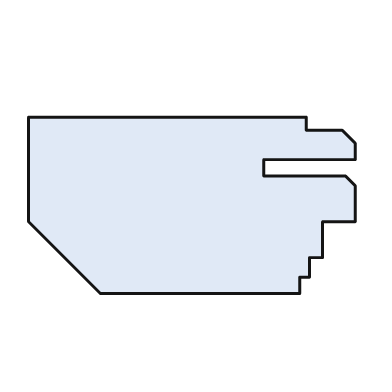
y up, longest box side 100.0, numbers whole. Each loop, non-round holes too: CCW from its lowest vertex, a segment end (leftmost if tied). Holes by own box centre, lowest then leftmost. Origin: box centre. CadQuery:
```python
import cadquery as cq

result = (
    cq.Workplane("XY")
    .moveTo(-28.0, -27.0)
    .lineTo(33.0, -27.0)
    .lineTo(33.0, -22.0)
    .lineTo(36.0, -22.0)
    .lineTo(36.0, -16.0)
    .lineTo(40.0, -16.0)
    .lineTo(40.0, -5.0)
    .lineTo(50.0, -5.0)
    .lineTo(50.0, 6.0)
    .lineTo(47.0, 9.0)
    .lineTo(22.0, 9.0)
    .lineTo(22.0, 14.0)
    .lineTo(50.0, 14.0)
    .lineTo(50.0, 19.0)
    .lineTo(46.0, 23.0)
    .lineTo(35.0, 23.0)
    .lineTo(35.0, 27.0)
    .lineTo(-50.0, 27.0)
    .lineTo(-50.0, -5.0)
    .close()
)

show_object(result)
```